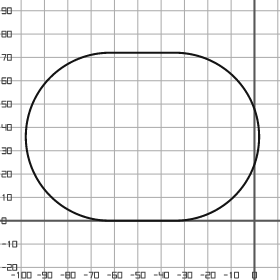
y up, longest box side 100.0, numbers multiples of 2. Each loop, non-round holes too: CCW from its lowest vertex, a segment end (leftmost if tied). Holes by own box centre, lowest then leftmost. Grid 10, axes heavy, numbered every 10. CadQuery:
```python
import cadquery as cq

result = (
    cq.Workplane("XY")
    .moveTo(-62.0, 0.0)
    .lineTo(-34.0, 0.0)
    .threePointArc((2.0, 36.0), (-34.0, 72.0))
    .lineTo(-62.0, 72.0)
    .threePointArc((-98.0, 36.0), (-62.0, 0.0))
    .close()
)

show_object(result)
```